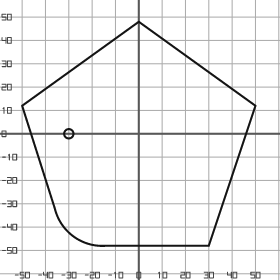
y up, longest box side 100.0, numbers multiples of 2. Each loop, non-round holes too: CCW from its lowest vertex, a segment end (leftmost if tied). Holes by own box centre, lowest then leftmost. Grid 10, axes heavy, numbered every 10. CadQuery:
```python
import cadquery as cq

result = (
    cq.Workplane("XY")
    .moveTo(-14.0, -48.0)
    .lineTo(30.0, -48.0)
    .lineTo(50.0, 12.0)
    .lineTo(0.0, 48.0)
    .lineTo(-50.0, 12.0)
    .lineTo(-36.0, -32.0)
    .threePointArc((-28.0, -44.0), (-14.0, -48.0))
    .close()
    .moveTo(-30.0, 0.0)
    .circle(2.0)
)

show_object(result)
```